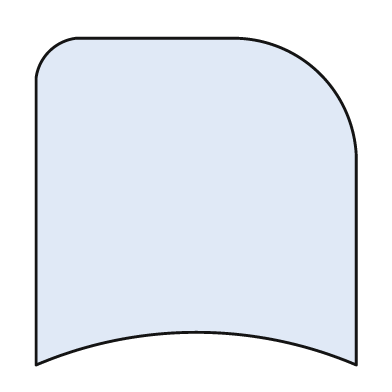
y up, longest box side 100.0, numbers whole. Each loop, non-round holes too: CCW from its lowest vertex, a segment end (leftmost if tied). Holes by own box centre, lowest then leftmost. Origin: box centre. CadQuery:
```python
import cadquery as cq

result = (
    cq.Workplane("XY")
    .moveTo(-49.0, -50.0)
    .threePointArc((0.0, -40.0), (49.0, -50.0))
    .lineTo(49.0, 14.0)
    .threePointArc((38.0, 39.0), (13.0, 50.0))
    .lineTo(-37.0, 50.0)
    .threePointArc((-45.0, 46.0), (-49.0, 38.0))
    .close()
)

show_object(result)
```